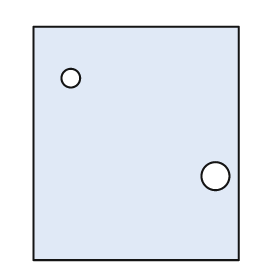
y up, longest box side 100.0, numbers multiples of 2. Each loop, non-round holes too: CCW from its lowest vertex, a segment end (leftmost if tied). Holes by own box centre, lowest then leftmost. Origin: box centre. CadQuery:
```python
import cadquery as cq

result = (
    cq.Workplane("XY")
    .moveTo(-44.0, -50.0)
    .lineTo(44.0, -50.0)
    .lineTo(44.0, 50.0)
    .lineTo(-44.0, 50.0)
    .close()
    .moveTo(34.0, -14.0)
    .circle(6.0)
    .moveTo(-28.0, 28.0)
    .circle(4.0)
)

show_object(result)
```